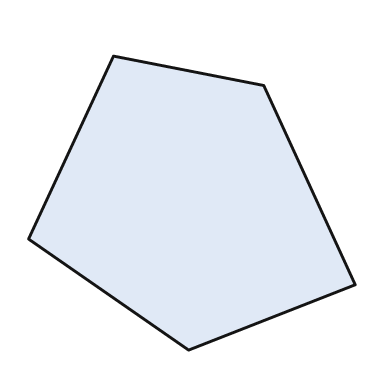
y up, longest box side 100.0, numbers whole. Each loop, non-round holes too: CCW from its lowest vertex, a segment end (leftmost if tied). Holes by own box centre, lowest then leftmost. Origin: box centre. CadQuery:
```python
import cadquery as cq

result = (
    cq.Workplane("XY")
    .moveTo(-1.0, -45.0)
    .lineTo(50.0, -25.0)
    .lineTo(22.0, 36.0)
    .lineTo(-24.0, 45.0)
    .lineTo(-50.0, -11.0)
    .close()
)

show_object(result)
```